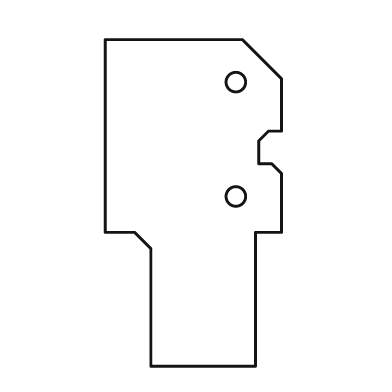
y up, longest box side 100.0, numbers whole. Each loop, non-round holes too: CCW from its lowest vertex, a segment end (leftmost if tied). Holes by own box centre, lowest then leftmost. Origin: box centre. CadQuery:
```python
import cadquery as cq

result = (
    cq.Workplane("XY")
    .moveTo(-13.0, -50.0)
    .lineTo(19.0, -50.0)
    .lineTo(19.0, -9.0)
    .lineTo(27.0, -9.0)
    .lineTo(27.0, 9.0)
    .lineTo(24.0, 12.0)
    .lineTo(20.0, 12.0)
    .lineTo(20.0, 19.0)
    .lineTo(23.0, 22.0)
    .lineTo(27.0, 22.0)
    .lineTo(27.0, 38.0)
    .lineTo(15.0, 50.0)
    .lineTo(-27.0, 50.0)
    .lineTo(-27.0, -9.0)
    .lineTo(-18.0, -9.0)
    .lineTo(-13.0, -14.0)
    .close()
    .moveTo(13.0, 2.0)
    .circle(3.0)
    .moveTo(13.0, 37.0)
    .circle(3.0)
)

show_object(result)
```